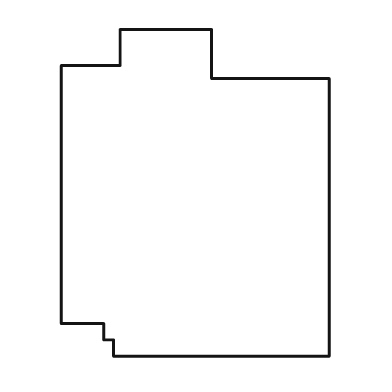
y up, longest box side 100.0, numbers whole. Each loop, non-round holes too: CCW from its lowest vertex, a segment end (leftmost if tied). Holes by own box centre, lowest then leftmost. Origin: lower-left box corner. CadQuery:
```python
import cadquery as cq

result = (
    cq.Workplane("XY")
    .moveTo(16.0, 0.0)
    .lineTo(82.0, 0.0)
    .lineTo(82.0, 85.0)
    .lineTo(46.0, 85.0)
    .lineTo(46.0, 100.0)
    .lineTo(18.0, 100.0)
    .lineTo(18.0, 89.0)
    .lineTo(0.0, 89.0)
    .lineTo(0.0, 10.0)
    .lineTo(13.0, 10.0)
    .lineTo(13.0, 5.0)
    .lineTo(16.0, 5.0)
    .close()
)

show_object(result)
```